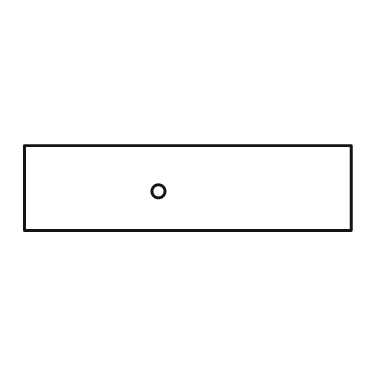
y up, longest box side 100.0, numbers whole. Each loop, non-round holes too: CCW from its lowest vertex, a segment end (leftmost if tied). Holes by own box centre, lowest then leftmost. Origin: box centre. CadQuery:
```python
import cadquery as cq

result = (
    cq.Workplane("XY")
    .moveTo(-50.0, -13.0)
    .lineTo(50.0, -13.0)
    .lineTo(50.0, 13.0)
    .lineTo(-50.0, 13.0)
    .close()
    .moveTo(-9.0, -1.0)
    .circle(2.0)
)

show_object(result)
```